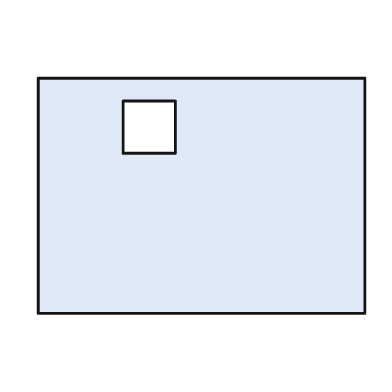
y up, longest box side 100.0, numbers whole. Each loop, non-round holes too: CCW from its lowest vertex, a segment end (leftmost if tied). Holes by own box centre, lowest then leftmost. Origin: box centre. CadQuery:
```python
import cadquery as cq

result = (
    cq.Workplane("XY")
    .moveTo(-50.0, -36.0)
    .lineTo(50.0, -36.0)
    .lineTo(50.0, 36.0)
    .lineTo(-50.0, 36.0)
    .close()
    .moveTo(-24.0, 13.0)
    .lineTo(-8.0, 13.0)
    .lineTo(-8.0, 29.0)
    .lineTo(-24.0, 29.0)
    .close()
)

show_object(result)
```